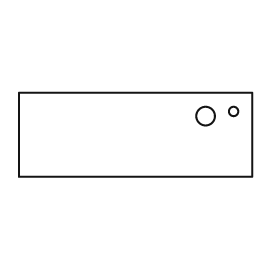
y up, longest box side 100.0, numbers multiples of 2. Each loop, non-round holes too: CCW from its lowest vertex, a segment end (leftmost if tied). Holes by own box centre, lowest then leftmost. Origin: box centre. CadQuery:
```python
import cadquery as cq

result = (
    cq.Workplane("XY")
    .moveTo(-50.0, -18.0)
    .lineTo(50.0, -18.0)
    .lineTo(50.0, 18.0)
    .lineTo(-50.0, 18.0)
    .close()
    .moveTo(30.0, 8.0)
    .circle(4.0)
    .moveTo(42.0, 10.0)
    .circle(2.0)
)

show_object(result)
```